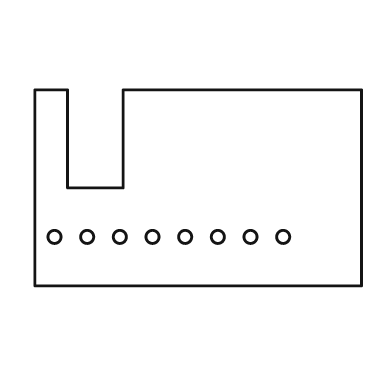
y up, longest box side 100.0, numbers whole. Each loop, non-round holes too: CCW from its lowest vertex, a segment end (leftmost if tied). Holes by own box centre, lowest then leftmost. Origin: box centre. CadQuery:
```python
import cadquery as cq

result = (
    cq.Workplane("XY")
    .moveTo(-50.0, -30.0)
    .lineTo(50.0, -30.0)
    .lineTo(50.0, 30.0)
    .lineTo(-23.0, 30.0)
    .lineTo(-23.0, 0.0)
    .lineTo(-40.0, 0.0)
    .lineTo(-40.0, 30.0)
    .lineTo(-50.0, 30.0)
    .close()
    .moveTo(-44.0, -15.0)
    .circle(2.0)
    .moveTo(-34.0, -15.0)
    .circle(2.0)
    .moveTo(-24.0, -15.0)
    .circle(2.0)
    .moveTo(-14.0, -15.0)
    .circle(2.0)
    .moveTo(-4.0, -15.0)
    .circle(2.0)
    .moveTo(6.0, -15.0)
    .circle(2.0)
    .moveTo(16.0, -15.0)
    .circle(2.0)
    .moveTo(26.0, -15.0)
    .circle(2.0)
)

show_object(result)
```